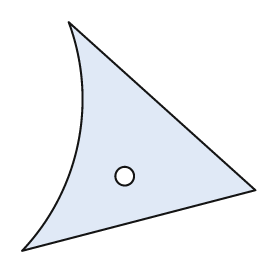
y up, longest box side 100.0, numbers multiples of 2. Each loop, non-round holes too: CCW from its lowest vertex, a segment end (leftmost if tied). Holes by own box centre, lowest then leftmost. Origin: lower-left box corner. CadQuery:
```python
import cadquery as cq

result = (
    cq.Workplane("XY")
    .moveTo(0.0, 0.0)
    .lineTo(100.0, 26.0)
    .lineTo(20.0, 98.0)
    .threePointArc((24.0, 46.0), (0.0, 0.0))
    .close()
    .moveTo(44.0, 32.0)
    .circle(4.0)
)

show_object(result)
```